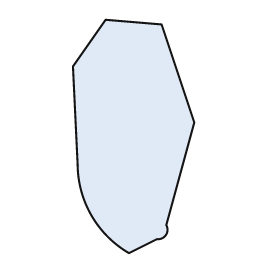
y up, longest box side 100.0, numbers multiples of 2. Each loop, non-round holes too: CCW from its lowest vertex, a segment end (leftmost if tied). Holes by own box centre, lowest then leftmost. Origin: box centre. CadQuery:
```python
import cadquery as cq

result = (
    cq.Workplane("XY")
    .moveTo(-2.0, -50.0)
    .lineTo(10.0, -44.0)
    .threePointArc((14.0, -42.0), (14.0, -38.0))
    .lineTo(26.0, 6.0)
    .lineTo(12.0, 48.0)
    .lineTo(-12.0, 50.0)
    .lineTo(-26.0, 30.0)
    .lineTo(-24.0, -12.0)
    .threePointArc((-18.0, -34.0), (-2.0, -50.0))
    .close()
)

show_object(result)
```